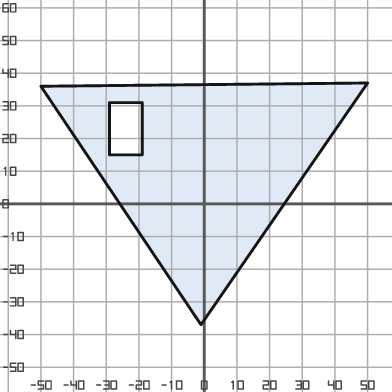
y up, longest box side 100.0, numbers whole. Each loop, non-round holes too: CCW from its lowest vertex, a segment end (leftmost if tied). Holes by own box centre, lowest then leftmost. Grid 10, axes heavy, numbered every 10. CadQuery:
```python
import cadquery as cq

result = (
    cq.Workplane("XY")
    .moveTo(-1.0, -37.0)
    .lineTo(50.0, 37.0)
    .lineTo(-50.0, 36.0)
    .close()
    .moveTo(-29.0, 15.0)
    .lineTo(-19.0, 15.0)
    .lineTo(-19.0, 31.0)
    .lineTo(-29.0, 31.0)
    .close()
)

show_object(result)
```